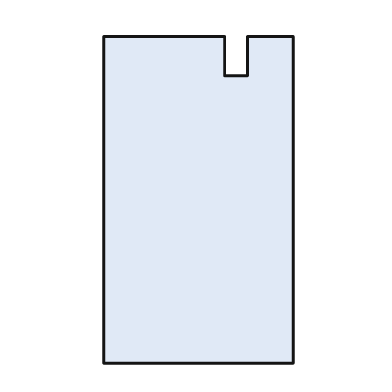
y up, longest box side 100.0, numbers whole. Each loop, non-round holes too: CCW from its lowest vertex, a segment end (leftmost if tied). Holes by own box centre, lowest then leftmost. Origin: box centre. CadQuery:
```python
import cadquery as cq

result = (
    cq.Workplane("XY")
    .moveTo(-29.0, -50.0)
    .lineTo(29.0, -50.0)
    .lineTo(29.0, 50.0)
    .lineTo(15.0, 50.0)
    .lineTo(15.0, 38.0)
    .lineTo(8.0, 38.0)
    .lineTo(8.0, 50.0)
    .lineTo(-29.0, 50.0)
    .close()
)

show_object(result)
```